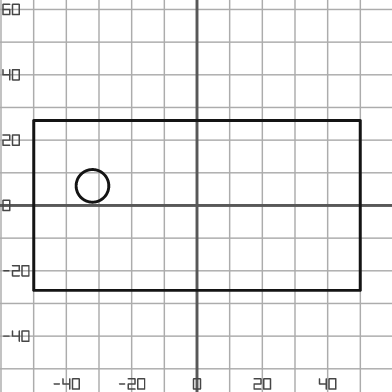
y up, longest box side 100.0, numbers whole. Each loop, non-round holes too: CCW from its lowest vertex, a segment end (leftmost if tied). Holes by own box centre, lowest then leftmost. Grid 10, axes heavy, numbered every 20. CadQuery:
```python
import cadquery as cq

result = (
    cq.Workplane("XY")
    .moveTo(-50.0, -26.0)
    .lineTo(50.0, -26.0)
    .lineTo(50.0, 26.0)
    .lineTo(-50.0, 26.0)
    .close()
    .moveTo(-32.0, 6.0)
    .circle(5.0)
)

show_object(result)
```